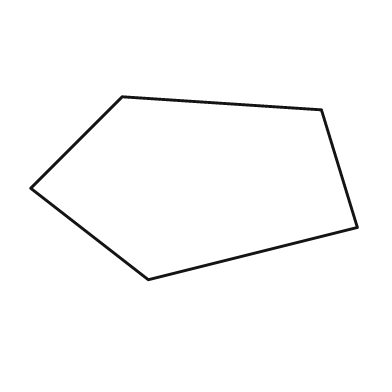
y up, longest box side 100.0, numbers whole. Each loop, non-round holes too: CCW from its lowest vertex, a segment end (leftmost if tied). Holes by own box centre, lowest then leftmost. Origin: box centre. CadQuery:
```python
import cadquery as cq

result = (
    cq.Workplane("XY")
    .moveTo(-14.0, -28.0)
    .lineTo(50.0, -12.0)
    .lineTo(39.0, 24.0)
    .lineTo(-22.0, 28.0)
    .lineTo(-50.0, 0.0)
    .close()
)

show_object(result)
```